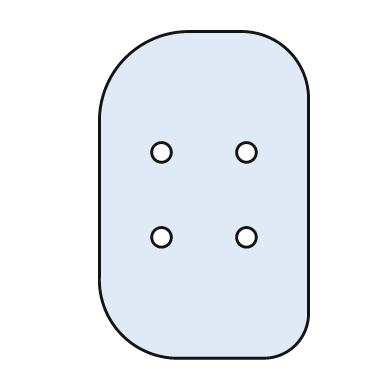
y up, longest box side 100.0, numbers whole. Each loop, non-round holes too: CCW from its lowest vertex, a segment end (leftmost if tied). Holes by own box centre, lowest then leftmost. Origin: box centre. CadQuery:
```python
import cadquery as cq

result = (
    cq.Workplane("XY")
    .moveTo(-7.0, -50.0)
    .lineTo(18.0, -50.0)
    .threePointArc((28.0, -46.0), (32.0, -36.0))
    .lineTo(32.0, 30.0)
    .threePointArc((26.0, 44.0), (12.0, 50.0))
    .lineTo(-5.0, 50.0)
    .threePointArc((-24.0, 42.0), (-32.0, 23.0))
    .lineTo(-32.0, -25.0)
    .threePointArc((-25.0, -43.0), (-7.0, -50.0))
    .close()
    .moveTo(-13.0, -13.0)
    .circle(3.0)
    .moveTo(13.0, -13.0)
    .circle(3.0)
    .moveTo(-13.0, 13.0)
    .circle(3.0)
    .moveTo(13.0, 13.0)
    .circle(3.0)
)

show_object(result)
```